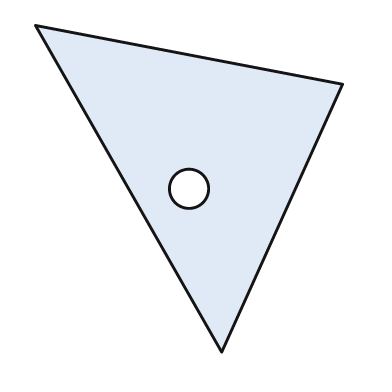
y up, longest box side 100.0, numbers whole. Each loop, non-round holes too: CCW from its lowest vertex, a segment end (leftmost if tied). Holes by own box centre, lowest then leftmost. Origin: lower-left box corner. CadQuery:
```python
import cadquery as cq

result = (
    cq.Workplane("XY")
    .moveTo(57.0, 0.0)
    .lineTo(94.0, 82.0)
    .lineTo(0.0, 100.0)
    .close()
    .moveTo(47.0, 50.0)
    .circle(6.0)
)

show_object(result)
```